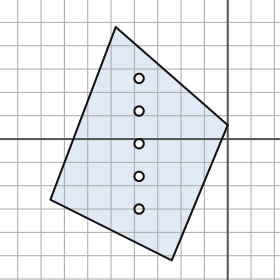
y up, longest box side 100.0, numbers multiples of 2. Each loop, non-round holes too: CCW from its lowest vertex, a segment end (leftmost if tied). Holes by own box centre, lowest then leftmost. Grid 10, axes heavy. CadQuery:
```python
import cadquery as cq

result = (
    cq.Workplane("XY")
    .moveTo(-24.0, -52.0)
    .lineTo(0.0, 6.0)
    .lineTo(-48.0, 48.0)
    .lineTo(-76.0, -26.0)
    .close()
    .moveTo(-38.0, -30.0)
    .circle(2.0)
    .moveTo(-38.0, -16.0)
    .circle(2.0)
    .moveTo(-38.0, -2.0)
    .circle(2.0)
    .moveTo(-38.0, 12.0)
    .circle(2.0)
    .moveTo(-38.0, 26.0)
    .circle(2.0)
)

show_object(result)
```